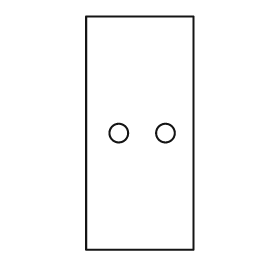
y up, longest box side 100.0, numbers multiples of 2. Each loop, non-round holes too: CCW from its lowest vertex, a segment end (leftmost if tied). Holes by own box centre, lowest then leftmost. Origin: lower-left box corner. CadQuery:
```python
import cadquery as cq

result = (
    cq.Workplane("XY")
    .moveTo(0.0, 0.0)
    .lineTo(46.0, 0.0)
    .lineTo(46.0, 100.0)
    .lineTo(0.0, 100.0)
    .close()
    .moveTo(14.0, 50.0)
    .circle(4.0)
    .moveTo(34.0, 50.0)
    .circle(4.0)
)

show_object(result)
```